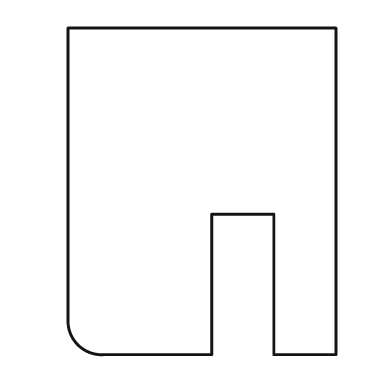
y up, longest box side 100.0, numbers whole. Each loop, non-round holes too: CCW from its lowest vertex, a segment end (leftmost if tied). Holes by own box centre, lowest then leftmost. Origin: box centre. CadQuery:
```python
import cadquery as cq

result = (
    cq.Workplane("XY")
    .moveTo(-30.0, -50.0)
    .lineTo(3.0, -50.0)
    .lineTo(3.0, -7.0)
    .lineTo(22.0, -7.0)
    .lineTo(22.0, -50.0)
    .lineTo(41.0, -50.0)
    .lineTo(41.0, 50.0)
    .lineTo(-41.0, 50.0)
    .lineTo(-41.0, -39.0)
    .threePointArc((-38.0, -47.0), (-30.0, -50.0))
    .close()
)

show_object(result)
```